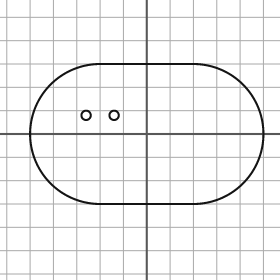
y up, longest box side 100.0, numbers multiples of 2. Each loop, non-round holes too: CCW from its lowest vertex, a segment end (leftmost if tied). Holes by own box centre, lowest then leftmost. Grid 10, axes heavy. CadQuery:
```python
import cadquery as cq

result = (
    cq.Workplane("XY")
    .moveTo(-20.0, -30.0)
    .lineTo(20.0, -30.0)
    .threePointArc((50.0, 0.0), (20.0, 30.0))
    .lineTo(-20.0, 30.0)
    .threePointArc((-50.0, 0.0), (-20.0, -30.0))
    .close()
    .moveTo(-26.0, 8.0)
    .circle(2.0)
    .moveTo(-14.0, 8.0)
    .circle(2.0)
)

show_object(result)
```